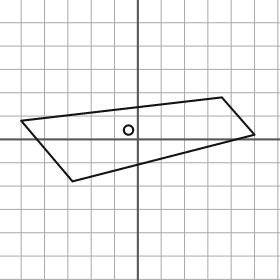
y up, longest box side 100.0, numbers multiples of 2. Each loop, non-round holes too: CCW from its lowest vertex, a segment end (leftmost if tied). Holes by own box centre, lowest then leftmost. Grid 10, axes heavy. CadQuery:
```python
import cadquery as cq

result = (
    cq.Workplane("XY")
    .moveTo(-28.0, -18.0)
    .lineTo(50.0, 2.0)
    .lineTo(36.0, 18.0)
    .lineTo(-50.0, 8.0)
    .close()
    .moveTo(-4.0, 4.0)
    .circle(2.0)
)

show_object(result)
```